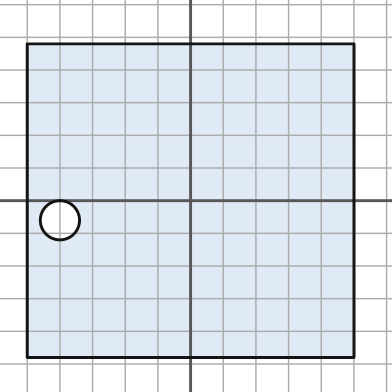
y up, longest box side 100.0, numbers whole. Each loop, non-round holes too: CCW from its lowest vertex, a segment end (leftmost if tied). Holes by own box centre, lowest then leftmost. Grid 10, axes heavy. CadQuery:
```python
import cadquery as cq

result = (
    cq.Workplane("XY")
    .moveTo(-50.0, -48.0)
    .lineTo(50.0, -48.0)
    .lineTo(50.0, 48.0)
    .lineTo(-50.0, 48.0)
    .close()
    .moveTo(-40.0, -6.0)
    .circle(6.0)
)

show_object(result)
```